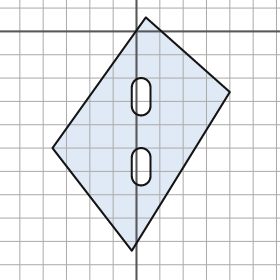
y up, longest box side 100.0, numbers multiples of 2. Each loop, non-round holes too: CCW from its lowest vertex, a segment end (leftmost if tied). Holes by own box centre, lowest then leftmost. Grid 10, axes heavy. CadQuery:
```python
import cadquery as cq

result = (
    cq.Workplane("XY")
    .moveTo(-2.0, -94.0)
    .lineTo(40.0, -26.0)
    .lineTo(4.0, 6.0)
    .lineTo(-36.0, -50.0)
    .close()
    .moveTo(-2.0, -62.0)
    .threePointArc((2.0, -66.0), (6.0, -62.0))
    .lineTo(6.0, -54.0)
    .threePointArc((2.0, -50.0), (-2.0, -54.0))
    .close()
    .moveTo(-2.0, -32.0)
    .threePointArc((2.0, -36.0), (6.0, -32.0))
    .lineTo(6.0, -24.0)
    .threePointArc((2.0, -20.0), (-2.0, -24.0))
    .close()
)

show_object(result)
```